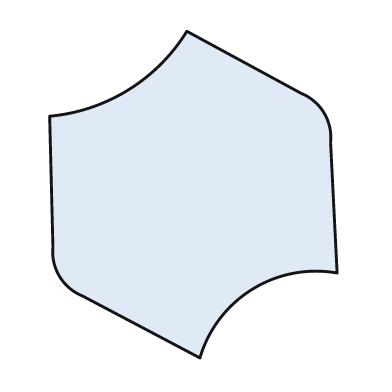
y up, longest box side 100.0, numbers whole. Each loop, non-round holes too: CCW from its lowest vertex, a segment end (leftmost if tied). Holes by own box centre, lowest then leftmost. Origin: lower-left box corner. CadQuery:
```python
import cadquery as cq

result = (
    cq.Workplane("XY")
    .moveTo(46.0, 0.0)
    .threePointArc((62.0, 21.0), (88.0, 26.0))
    .lineTo(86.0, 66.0)
    .threePointArc((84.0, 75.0), (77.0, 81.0))
    .lineTo(42.0, 100.0)
    .threePointArc((24.0, 82.0), (0.0, 74.0))
    .lineTo(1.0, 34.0)
    .threePointArc((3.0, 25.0), (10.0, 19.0))
    .close()
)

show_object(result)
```